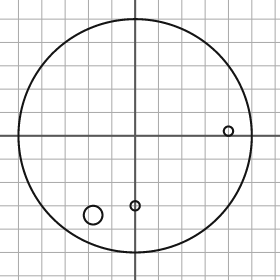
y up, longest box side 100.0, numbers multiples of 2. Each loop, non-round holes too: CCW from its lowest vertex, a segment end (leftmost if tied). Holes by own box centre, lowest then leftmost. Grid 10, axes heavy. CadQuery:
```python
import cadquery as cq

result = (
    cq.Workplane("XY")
    .moveTo(0.0, 0.0)
    .circle(50.0)
    .moveTo(-18.0, -34.0)
    .circle(4.0)
    .moveTo(0.0, -30.0)
    .circle(2.0)
    .moveTo(40.0, 2.0)
    .circle(2.0)
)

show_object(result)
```